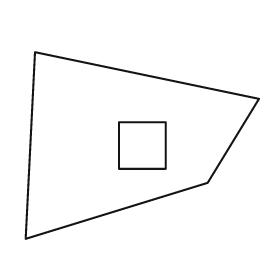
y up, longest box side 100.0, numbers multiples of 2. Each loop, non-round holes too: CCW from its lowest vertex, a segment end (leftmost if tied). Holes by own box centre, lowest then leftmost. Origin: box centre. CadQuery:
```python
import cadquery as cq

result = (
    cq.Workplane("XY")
    .moveTo(-50.0, -40.0)
    .lineTo(28.0, -16.0)
    .lineTo(50.0, 20.0)
    .lineTo(-46.0, 40.0)
    .close()
    .moveTo(-10.0, -10.0)
    .lineTo(10.0, -10.0)
    .lineTo(10.0, 10.0)
    .lineTo(-10.0, 10.0)
    .close()
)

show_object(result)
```